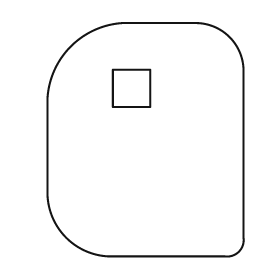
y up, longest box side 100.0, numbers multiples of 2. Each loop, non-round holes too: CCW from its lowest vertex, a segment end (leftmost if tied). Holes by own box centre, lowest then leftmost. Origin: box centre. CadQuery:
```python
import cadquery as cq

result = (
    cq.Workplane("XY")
    .moveTo(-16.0, -50.0)
    .lineTo(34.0, -50.0)
    .threePointArc((40.0, -48.0), (42.0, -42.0))
    .lineTo(42.0, 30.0)
    .threePointArc((36.0, 44.0), (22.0, 50.0))
    .lineTo(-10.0, 50.0)
    .threePointArc((-32.0, 40.0), (-42.0, 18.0))
    .lineTo(-42.0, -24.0)
    .threePointArc((-34.0, -42.0), (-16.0, -50.0))
    .close()
    .moveTo(-14.0, 14.0)
    .lineTo(2.0, 14.0)
    .lineTo(2.0, 30.0)
    .lineTo(-14.0, 30.0)
    .close()
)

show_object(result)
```